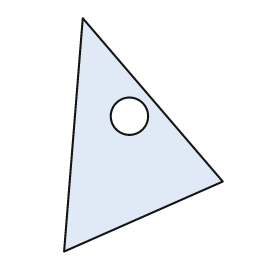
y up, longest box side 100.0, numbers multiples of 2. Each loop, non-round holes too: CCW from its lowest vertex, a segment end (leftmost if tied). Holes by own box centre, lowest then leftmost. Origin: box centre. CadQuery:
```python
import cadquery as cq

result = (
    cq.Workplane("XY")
    .moveTo(-34.0, -50.0)
    .lineTo(34.0, -20.0)
    .lineTo(-26.0, 50.0)
    .close()
    .moveTo(-6.0, 8.0)
    .circle(8.0)
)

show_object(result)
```